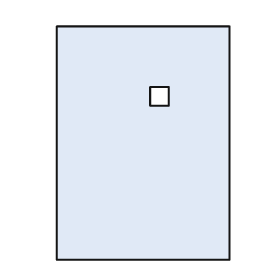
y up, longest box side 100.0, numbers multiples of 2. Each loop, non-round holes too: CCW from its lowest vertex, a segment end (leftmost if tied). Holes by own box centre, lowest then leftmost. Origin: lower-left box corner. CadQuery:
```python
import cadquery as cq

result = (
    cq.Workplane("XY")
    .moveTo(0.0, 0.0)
    .lineTo(74.0, 0.0)
    .lineTo(74.0, 100.0)
    .lineTo(0.0, 100.0)
    .close()
    .moveTo(40.0, 66.0)
    .lineTo(48.0, 66.0)
    .lineTo(48.0, 74.0)
    .lineTo(40.0, 74.0)
    .close()
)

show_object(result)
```